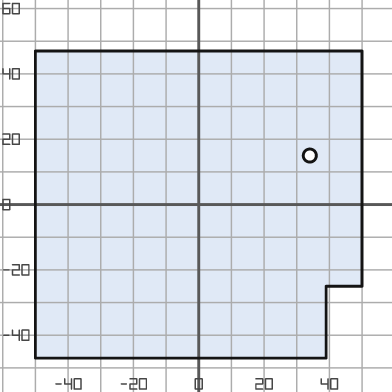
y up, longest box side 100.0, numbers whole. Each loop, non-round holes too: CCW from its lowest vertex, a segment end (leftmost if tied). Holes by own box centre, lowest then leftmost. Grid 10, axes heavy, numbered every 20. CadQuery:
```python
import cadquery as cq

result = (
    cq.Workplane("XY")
    .moveTo(-50.0, -47.0)
    .lineTo(39.0, -47.0)
    .lineTo(39.0, -25.0)
    .lineTo(50.0, -25.0)
    .lineTo(50.0, 47.0)
    .lineTo(-50.0, 47.0)
    .close()
    .moveTo(34.0, 15.0)
    .circle(2.0)
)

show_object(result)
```